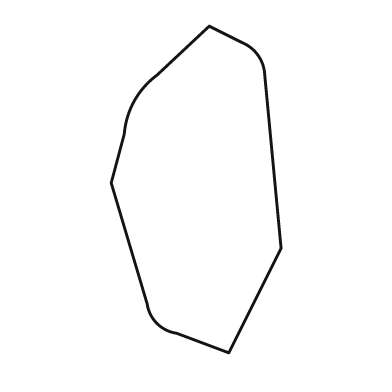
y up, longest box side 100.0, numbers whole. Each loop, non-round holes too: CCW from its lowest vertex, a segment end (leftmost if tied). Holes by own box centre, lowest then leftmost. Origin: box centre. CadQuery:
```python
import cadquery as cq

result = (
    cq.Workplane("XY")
    .moveTo(10.0, -50.0)
    .lineTo(26.0, -18.0)
    .lineTo(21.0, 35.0)
    .threePointArc((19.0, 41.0), (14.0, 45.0))
    .lineTo(4.0, 50.0)
    .lineTo(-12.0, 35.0)
    .threePointArc((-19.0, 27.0), (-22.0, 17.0))
    .lineTo(-26.0, 2.0)
    .lineTo(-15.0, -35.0)
    .threePointArc((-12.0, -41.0), (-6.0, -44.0))
    .close()
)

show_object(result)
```